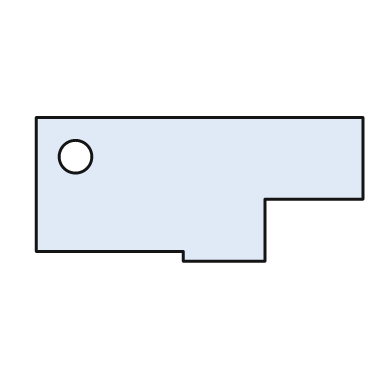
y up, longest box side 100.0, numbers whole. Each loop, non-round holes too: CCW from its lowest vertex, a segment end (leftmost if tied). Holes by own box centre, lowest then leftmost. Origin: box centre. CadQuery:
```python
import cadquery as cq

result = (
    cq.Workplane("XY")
    .moveTo(-5.0, -22.0)
    .lineTo(20.0, -22.0)
    .lineTo(20.0, -3.0)
    .lineTo(50.0, -3.0)
    .lineTo(50.0, 22.0)
    .lineTo(-50.0, 22.0)
    .lineTo(-50.0, -19.0)
    .lineTo(-5.0, -19.0)
    .close()
    .moveTo(-38.0, 10.0)
    .circle(5.0)
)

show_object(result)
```